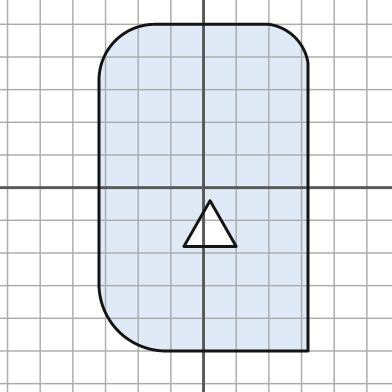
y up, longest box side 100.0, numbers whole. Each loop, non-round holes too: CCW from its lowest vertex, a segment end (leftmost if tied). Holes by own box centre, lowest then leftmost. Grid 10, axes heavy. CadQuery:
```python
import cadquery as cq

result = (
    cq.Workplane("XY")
    .moveTo(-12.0, -50.0)
    .lineTo(32.0, -50.0)
    .lineTo(32.0, 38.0)
    .threePointArc((28.0, 46.0), (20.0, 50.0))
    .lineTo(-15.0, 50.0)
    .threePointArc((-27.0, 45.0), (-32.0, 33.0))
    .lineTo(-32.0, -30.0)
    .threePointArc((-26.0, -44.0), (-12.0, -50.0))
    .close()
    .moveTo(-6.0, -18.0)
    .lineTo(10.0, -18.0)
    .lineTo(2.0, -4.0)
    .close()
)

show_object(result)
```